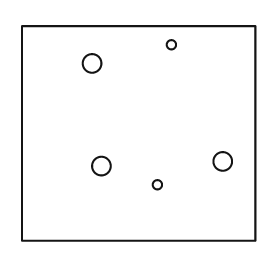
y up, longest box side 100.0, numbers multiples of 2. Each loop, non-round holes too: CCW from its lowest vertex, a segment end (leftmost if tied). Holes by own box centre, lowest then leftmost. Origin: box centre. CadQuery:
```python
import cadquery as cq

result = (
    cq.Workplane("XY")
    .moveTo(-50.0, -46.0)
    .lineTo(50.0, -46.0)
    .lineTo(50.0, 46.0)
    .lineTo(-50.0, 46.0)
    .close()
    .moveTo(8.0, -22.0)
    .circle(2.0)
    .moveTo(-16.0, -14.0)
    .circle(4.0)
    .moveTo(36.0, -12.0)
    .circle(4.0)
    .moveTo(-20.0, 30.0)
    .circle(4.0)
    .moveTo(14.0, 38.0)
    .circle(2.0)
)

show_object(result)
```